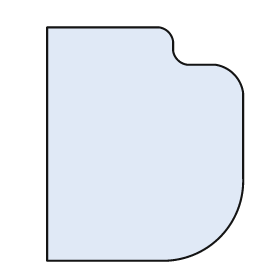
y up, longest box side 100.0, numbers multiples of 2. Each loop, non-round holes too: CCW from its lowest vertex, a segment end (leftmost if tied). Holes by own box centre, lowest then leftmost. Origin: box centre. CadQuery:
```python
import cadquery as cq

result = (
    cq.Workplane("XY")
    .moveTo(-42.0, -50.0)
    .lineTo(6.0, -50.0)
    .threePointArc((32.0, -40.0), (42.0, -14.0))
    .lineTo(42.0, 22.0)
    .threePointArc((38.0, 30.0), (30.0, 34.0))
    .lineTo(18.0, 34.0)
    .threePointArc((14.0, 36.0), (12.0, 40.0))
    .lineTo(12.0, 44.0)
    .threePointArc((10.0, 48.0), (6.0, 50.0))
    .lineTo(-42.0, 50.0)
    .close()
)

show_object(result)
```